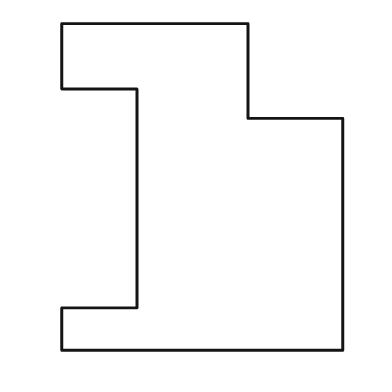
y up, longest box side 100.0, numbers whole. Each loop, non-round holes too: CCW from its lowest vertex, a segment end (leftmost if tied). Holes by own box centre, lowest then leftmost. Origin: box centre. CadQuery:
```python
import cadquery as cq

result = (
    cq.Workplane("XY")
    .moveTo(-43.0, -50.0)
    .lineTo(43.0, -50.0)
    .lineTo(43.0, 21.0)
    .lineTo(14.0, 21.0)
    .lineTo(14.0, 50.0)
    .lineTo(-43.0, 50.0)
    .lineTo(-43.0, 30.0)
    .lineTo(-20.0, 30.0)
    .lineTo(-20.0, -37.0)
    .lineTo(-43.0, -37.0)
    .close()
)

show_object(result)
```